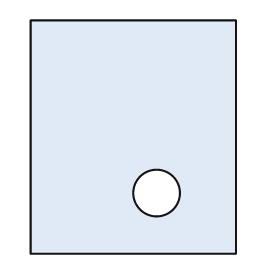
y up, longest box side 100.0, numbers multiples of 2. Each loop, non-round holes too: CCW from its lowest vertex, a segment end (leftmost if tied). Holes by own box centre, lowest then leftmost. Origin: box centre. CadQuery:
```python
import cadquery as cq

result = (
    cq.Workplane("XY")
    .moveTo(-44.0, -50.0)
    .lineTo(44.0, -50.0)
    .lineTo(44.0, 50.0)
    .lineTo(-44.0, 50.0)
    .close()
    .moveTo(10.0, -24.0)
    .circle(10.0)
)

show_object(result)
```